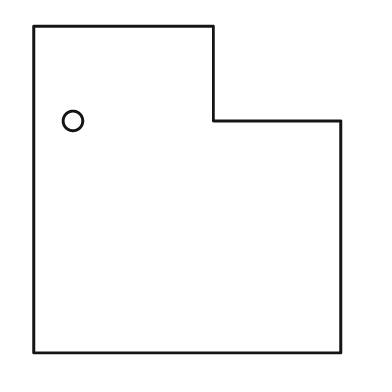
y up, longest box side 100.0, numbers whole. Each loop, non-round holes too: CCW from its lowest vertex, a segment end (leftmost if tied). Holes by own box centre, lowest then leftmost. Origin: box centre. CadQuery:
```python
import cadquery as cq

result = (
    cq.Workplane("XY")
    .moveTo(-47.0, -50.0)
    .lineTo(47.0, -50.0)
    .lineTo(47.0, 21.0)
    .lineTo(8.0, 21.0)
    .lineTo(8.0, 50.0)
    .lineTo(-47.0, 50.0)
    .close()
    .moveTo(-35.0, 21.0)
    .circle(3.0)
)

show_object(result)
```